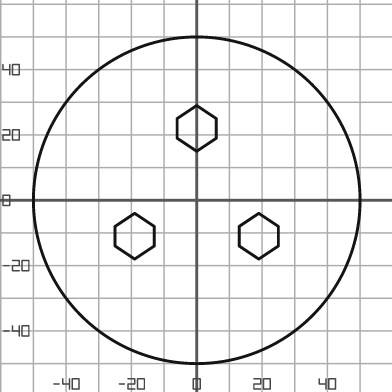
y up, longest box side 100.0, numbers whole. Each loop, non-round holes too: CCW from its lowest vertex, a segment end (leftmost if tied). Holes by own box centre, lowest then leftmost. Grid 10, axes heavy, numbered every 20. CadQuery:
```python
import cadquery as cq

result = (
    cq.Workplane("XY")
    .moveTo(0.0, 0.0)
    .circle(50.0)
    .moveTo(-19.0, -18.0)
    .lineTo(-13.0, -14.0)
    .lineTo(-13.0, -8.0)
    .lineTo(-19.0, -4.0)
    .lineTo(-25.0, -8.0)
    .lineTo(-25.0, -14.0)
    .close()
    .moveTo(19.0, -18.0)
    .lineTo(25.0, -14.0)
    .lineTo(25.0, -8.0)
    .lineTo(19.0, -4.0)
    .lineTo(13.0, -8.0)
    .lineTo(13.0, -14.0)
    .close()
    .moveTo(0.0, 15.0)
    .lineTo(6.0, 19.0)
    .lineTo(6.0, 25.0)
    .lineTo(0.0, 29.0)
    .lineTo(-6.0, 25.0)
    .lineTo(-6.0, 19.0)
    .close()
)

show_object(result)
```